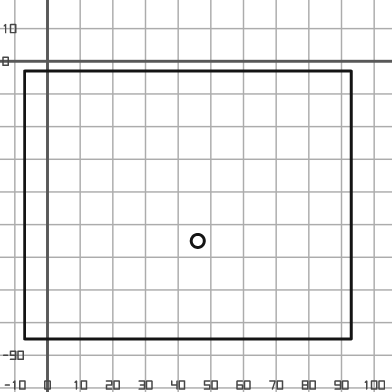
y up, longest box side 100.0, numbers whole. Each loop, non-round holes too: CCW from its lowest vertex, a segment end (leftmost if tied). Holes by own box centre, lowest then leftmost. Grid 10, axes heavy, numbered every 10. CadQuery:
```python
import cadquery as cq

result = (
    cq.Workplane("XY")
    .moveTo(-7.0, -85.0)
    .lineTo(93.0, -85.0)
    .lineTo(93.0, -3.0)
    .lineTo(-7.0, -3.0)
    .close()
    .moveTo(46.0, -55.0)
    .circle(2.0)
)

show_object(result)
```